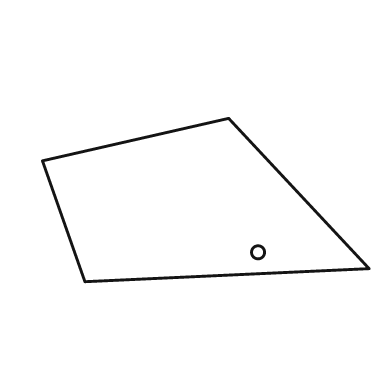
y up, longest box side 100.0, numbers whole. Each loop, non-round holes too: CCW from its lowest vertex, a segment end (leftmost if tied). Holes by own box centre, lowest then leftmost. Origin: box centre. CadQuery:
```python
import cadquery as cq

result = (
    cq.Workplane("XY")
    .moveTo(-37.0, -25.0)
    .lineTo(50.0, -21.0)
    .lineTo(7.0, 25.0)
    .lineTo(-50.0, 12.0)
    .close()
    .moveTo(16.0, -16.0)
    .circle(2.0)
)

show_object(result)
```